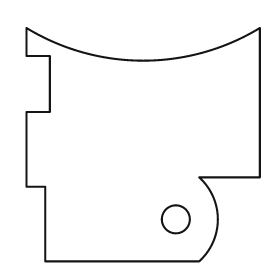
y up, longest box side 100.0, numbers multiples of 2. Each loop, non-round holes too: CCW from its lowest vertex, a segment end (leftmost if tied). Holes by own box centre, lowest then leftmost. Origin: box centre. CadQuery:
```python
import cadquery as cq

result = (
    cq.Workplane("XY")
    .moveTo(-42.0, -50.0)
    .lineTo(24.0, -50.0)
    .threePointArc((32.0, -32.0), (24.0, -14.0))
    .lineTo(50.0, -14.0)
    .lineTo(50.0, 50.0)
    .threePointArc((0.0, 36.0), (-50.0, 50.0))
    .lineTo(-50.0, 38.0)
    .lineTo(-40.0, 38.0)
    .lineTo(-40.0, 14.0)
    .lineTo(-50.0, 14.0)
    .lineTo(-50.0, -18.0)
    .lineTo(-42.0, -18.0)
    .close()
    .moveTo(14.0, -32.0)
    .circle(6.0)
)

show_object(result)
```